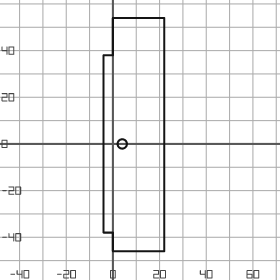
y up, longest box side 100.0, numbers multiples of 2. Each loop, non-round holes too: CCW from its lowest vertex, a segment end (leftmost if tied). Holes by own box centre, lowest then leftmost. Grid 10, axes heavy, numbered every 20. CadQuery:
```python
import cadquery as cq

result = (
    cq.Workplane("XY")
    .moveTo(0.0, -46.0)
    .lineTo(22.0, -46.0)
    .lineTo(22.0, 54.0)
    .lineTo(0.0, 54.0)
    .lineTo(0.0, 38.0)
    .lineTo(-4.0, 38.0)
    .lineTo(-4.0, -38.0)
    .lineTo(0.0, -38.0)
    .close()
    .moveTo(4.0, 0.0)
    .circle(2.0)
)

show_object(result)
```